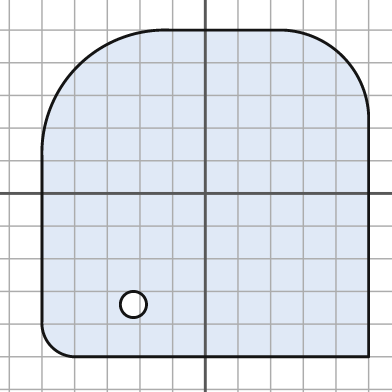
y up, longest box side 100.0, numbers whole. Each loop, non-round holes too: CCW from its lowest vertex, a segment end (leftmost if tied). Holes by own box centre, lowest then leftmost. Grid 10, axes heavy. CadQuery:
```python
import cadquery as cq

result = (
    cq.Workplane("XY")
    .moveTo(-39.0, -50.0)
    .lineTo(50.0, -50.0)
    .lineTo(50.0, 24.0)
    .threePointArc((42.0, 42.0), (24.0, 50.0))
    .lineTo(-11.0, 50.0)
    .threePointArc((-39.0, 39.0), (-50.0, 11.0))
    .lineTo(-50.0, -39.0)
    .threePointArc((-47.0, -47.0), (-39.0, -50.0))
    .close()
    .moveTo(-22.0, -34.0)
    .circle(4.0)
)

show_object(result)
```